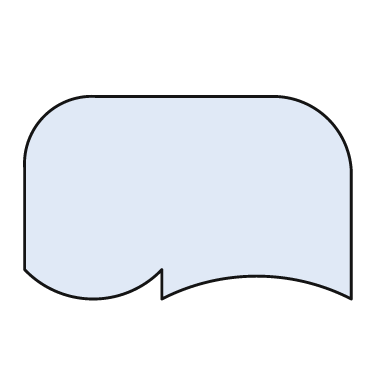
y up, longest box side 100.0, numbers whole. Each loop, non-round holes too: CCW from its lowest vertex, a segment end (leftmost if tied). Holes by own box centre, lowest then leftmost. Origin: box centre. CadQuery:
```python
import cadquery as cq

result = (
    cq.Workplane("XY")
    .moveTo(-8.0, -31.0)
    .threePointArc((21.0, -24.0), (50.0, -31.0))
    .lineTo(50.0, 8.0)
    .threePointArc((43.0, 24.0), (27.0, 31.0))
    .lineTo(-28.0, 31.0)
    .threePointArc((-44.0, 25.0), (-50.0, 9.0))
    .lineTo(-50.0, -22.0)
    .threePointArc((-29.0, -31.0), (-8.0, -22.0))
    .close()
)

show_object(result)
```